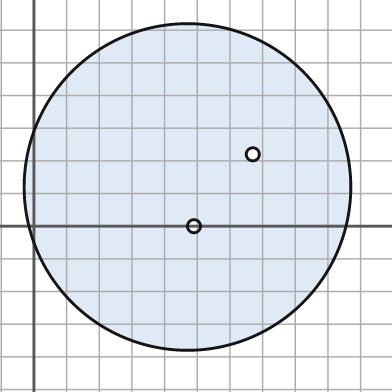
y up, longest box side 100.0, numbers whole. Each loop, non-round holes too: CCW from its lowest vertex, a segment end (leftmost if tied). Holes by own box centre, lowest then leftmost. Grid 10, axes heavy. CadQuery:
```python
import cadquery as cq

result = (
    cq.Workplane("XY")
    .moveTo(47.0, 12.0)
    .circle(50.0)
    .moveTo(49.0, 0.0)
    .circle(2.0)
    .moveTo(67.0, 22.0)
    .circle(2.0)
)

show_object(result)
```